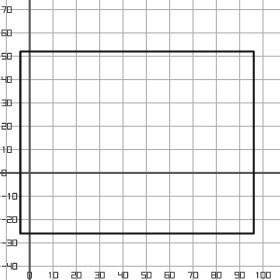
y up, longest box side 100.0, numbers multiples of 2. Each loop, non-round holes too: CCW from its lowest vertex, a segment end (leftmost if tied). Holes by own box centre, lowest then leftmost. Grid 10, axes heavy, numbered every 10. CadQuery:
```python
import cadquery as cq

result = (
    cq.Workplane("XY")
    .moveTo(-4.0, -26.0)
    .lineTo(96.0, -26.0)
    .lineTo(96.0, 52.0)
    .lineTo(-4.0, 52.0)
    .close()
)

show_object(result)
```